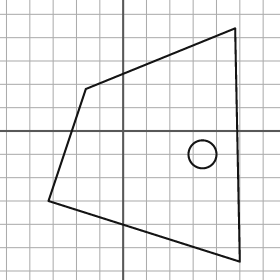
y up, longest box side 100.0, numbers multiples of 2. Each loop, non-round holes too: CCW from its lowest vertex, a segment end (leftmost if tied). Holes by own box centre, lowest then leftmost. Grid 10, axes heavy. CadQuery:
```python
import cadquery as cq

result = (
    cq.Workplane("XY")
    .moveTo(50.0, -56.0)
    .lineTo(48.0, 44.0)
    .lineTo(-16.0, 18.0)
    .lineTo(-32.0, -30.0)
    .close()
    .moveTo(34.0, -10.0)
    .circle(6.0)
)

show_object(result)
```